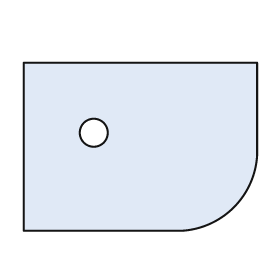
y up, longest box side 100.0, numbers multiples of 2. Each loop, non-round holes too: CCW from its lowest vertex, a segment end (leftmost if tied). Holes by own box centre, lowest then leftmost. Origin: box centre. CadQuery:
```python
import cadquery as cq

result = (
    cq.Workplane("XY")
    .moveTo(-50.0, -36.0)
    .lineTo(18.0, -36.0)
    .threePointArc((40.0, -26.0), (50.0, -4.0))
    .lineTo(50.0, 36.0)
    .lineTo(-50.0, 36.0)
    .close()
    .moveTo(-20.0, 6.0)
    .circle(6.0)
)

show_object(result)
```